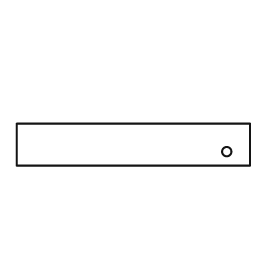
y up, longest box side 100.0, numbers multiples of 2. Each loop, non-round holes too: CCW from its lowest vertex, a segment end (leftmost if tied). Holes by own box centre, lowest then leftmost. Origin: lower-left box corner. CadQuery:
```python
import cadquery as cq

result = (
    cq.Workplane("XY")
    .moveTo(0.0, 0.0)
    .lineTo(100.0, 0.0)
    .lineTo(100.0, 18.0)
    .lineTo(0.0, 18.0)
    .close()
    .moveTo(90.0, 6.0)
    .circle(2.0)
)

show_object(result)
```